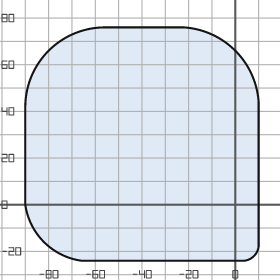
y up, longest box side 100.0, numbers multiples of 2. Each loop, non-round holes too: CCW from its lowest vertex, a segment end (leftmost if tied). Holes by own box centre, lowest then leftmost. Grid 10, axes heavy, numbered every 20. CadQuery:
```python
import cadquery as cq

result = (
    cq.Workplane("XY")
    .moveTo(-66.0, -24.0)
    .lineTo(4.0, -24.0)
    .threePointArc((8.0, -22.0), (10.0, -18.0))
    .lineTo(10.0, 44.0)
    .threePointArc((0.0, 66.0), (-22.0, 76.0))
    .lineTo(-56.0, 76.0)
    .threePointArc((-80.0, 66.0), (-90.0, 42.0))
    .lineTo(-90.0, 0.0)
    .threePointArc((-82.0, -16.0), (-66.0, -24.0))
    .close()
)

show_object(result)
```